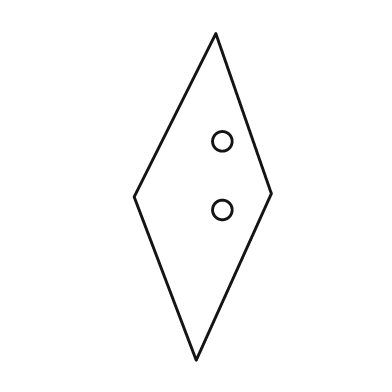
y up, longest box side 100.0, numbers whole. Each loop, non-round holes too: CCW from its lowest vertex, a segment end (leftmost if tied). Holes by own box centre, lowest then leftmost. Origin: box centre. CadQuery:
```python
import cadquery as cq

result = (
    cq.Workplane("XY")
    .moveTo(-2.0, -50.0)
    .lineTo(21.0, 1.0)
    .lineTo(4.0, 50.0)
    .lineTo(-21.0, 0.0)
    .close()
    .moveTo(6.0, -4.0)
    .circle(3.0)
    .moveTo(6.0, 17.0)
    .circle(3.0)
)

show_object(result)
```